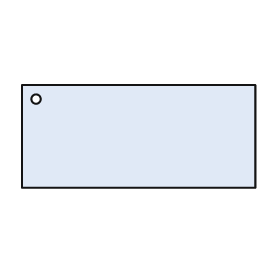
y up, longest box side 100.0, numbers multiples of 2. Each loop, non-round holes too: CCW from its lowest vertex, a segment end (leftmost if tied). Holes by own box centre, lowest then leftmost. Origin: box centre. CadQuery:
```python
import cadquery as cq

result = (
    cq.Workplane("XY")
    .moveTo(-50.0, -22.0)
    .lineTo(50.0, -22.0)
    .lineTo(50.0, 22.0)
    .lineTo(-50.0, 22.0)
    .close()
    .moveTo(-44.0, 16.0)
    .circle(2.0)
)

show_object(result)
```